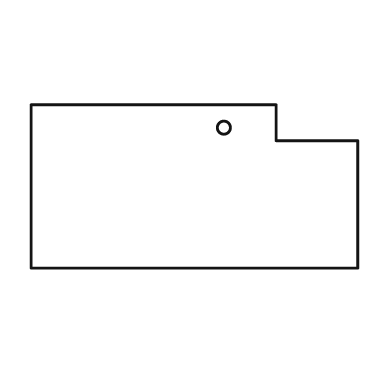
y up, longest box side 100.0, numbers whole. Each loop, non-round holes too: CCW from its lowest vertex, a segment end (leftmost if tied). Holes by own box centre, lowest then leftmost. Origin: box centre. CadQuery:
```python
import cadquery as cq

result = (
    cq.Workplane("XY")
    .moveTo(-50.0, -25.0)
    .lineTo(50.0, -25.0)
    .lineTo(50.0, 14.0)
    .lineTo(25.0, 14.0)
    .lineTo(25.0, 25.0)
    .lineTo(-50.0, 25.0)
    .close()
    .moveTo(9.0, 18.0)
    .circle(2.0)
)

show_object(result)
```